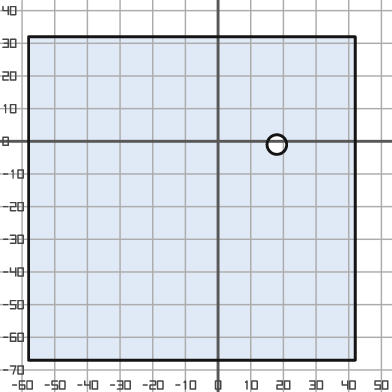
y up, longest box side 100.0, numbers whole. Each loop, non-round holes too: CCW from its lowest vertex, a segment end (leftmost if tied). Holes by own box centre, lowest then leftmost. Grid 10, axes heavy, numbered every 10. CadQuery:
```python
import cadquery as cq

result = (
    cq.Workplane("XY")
    .moveTo(-58.0, -67.0)
    .lineTo(42.0, -67.0)
    .lineTo(42.0, 32.0)
    .lineTo(-58.0, 32.0)
    .close()
    .moveTo(18.0, -1.0)
    .circle(3.0)
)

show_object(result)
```